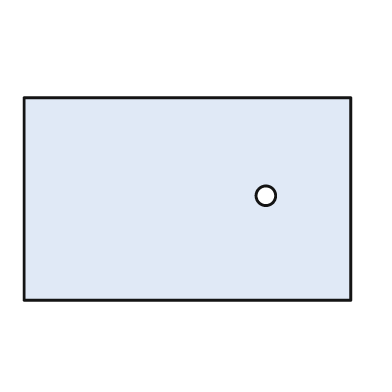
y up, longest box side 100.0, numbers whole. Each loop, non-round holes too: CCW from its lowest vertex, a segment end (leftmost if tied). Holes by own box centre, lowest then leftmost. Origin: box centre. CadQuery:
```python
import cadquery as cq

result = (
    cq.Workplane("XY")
    .moveTo(-50.0, -31.0)
    .lineTo(50.0, -31.0)
    .lineTo(50.0, 31.0)
    .lineTo(-50.0, 31.0)
    .close()
    .moveTo(24.0, 1.0)
    .circle(3.0)
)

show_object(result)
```